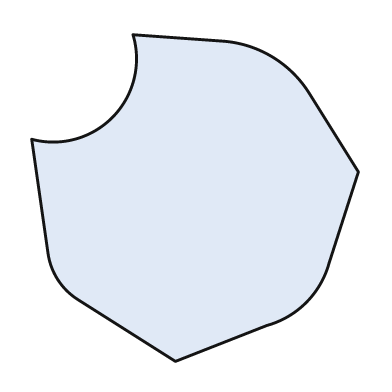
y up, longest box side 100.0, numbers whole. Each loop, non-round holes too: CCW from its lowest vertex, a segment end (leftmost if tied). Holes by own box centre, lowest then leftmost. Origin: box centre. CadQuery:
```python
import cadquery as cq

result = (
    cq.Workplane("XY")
    .moveTo(-6.0, -50.0)
    .lineTo(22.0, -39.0)
    .threePointArc((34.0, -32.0), (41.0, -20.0))
    .lineTo(50.0, 8.0)
    .lineTo(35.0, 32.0)
    .threePointArc((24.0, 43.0), (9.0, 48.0))
    .lineTo(-19.0, 50.0)
    .threePointArc((-25.0, 25.0), (-50.0, 18.0))
    .lineTo(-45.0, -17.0)
    .threePointArc((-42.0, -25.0), (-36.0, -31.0))
    .close()
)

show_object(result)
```